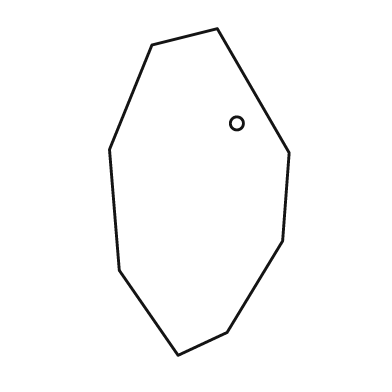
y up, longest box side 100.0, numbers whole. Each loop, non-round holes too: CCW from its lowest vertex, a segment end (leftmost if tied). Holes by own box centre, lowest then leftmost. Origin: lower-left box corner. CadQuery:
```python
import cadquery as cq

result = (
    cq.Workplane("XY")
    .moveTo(21.0, 0.0)
    .lineTo(36.0, 7.0)
    .lineTo(53.0, 35.0)
    .lineTo(55.0, 62.0)
    .lineTo(33.0, 100.0)
    .lineTo(13.0, 95.0)
    .lineTo(0.0, 63.0)
    .lineTo(3.0, 26.0)
    .close()
    .moveTo(39.0, 71.0)
    .circle(2.0)
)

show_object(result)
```